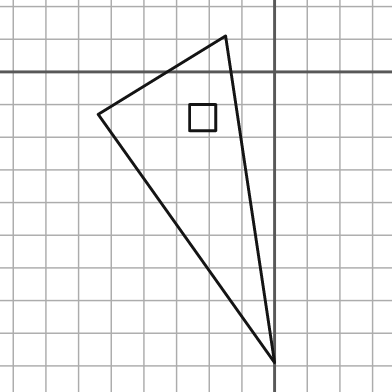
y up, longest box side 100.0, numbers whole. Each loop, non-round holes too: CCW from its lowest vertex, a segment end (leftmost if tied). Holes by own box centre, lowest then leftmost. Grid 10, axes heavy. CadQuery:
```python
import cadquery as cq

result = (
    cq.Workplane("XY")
    .moveTo(0.0, -89.0)
    .lineTo(-15.0, 11.0)
    .lineTo(-54.0, -13.0)
    .close()
    .moveTo(-26.0, -18.0)
    .lineTo(-18.0, -18.0)
    .lineTo(-18.0, -10.0)
    .lineTo(-26.0, -10.0)
    .close()
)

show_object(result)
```